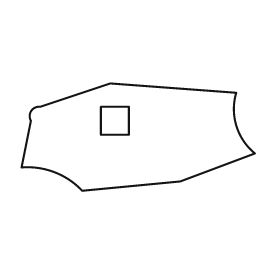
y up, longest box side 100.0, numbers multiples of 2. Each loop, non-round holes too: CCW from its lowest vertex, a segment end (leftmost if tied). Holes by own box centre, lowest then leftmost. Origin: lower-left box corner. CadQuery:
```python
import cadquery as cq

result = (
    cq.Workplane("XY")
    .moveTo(26.0, 0.0)
    .lineTo(68.0, 4.0)
    .lineTo(100.0, 16.0)
    .threePointArc((92.0, 28.0), (92.0, 42.0))
    .lineTo(38.0, 46.0)
    .lineTo(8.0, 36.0)
    .threePointArc((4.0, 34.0), (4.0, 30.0))
    .lineTo(0.0, 10.0)
    .threePointArc((14.0, 8.0), (26.0, 0.0))
    .close()
    .moveTo(34.0, 24.0)
    .lineTo(46.0, 24.0)
    .lineTo(46.0, 36.0)
    .lineTo(34.0, 36.0)
    .close()
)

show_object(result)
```